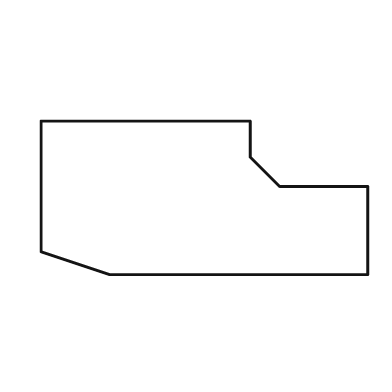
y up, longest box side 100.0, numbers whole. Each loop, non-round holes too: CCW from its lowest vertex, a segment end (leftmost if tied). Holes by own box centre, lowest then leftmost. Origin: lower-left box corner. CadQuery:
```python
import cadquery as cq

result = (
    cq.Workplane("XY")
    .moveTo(21.0, 0.0)
    .lineTo(100.0, 0.0)
    .lineTo(100.0, 27.0)
    .lineTo(73.0, 27.0)
    .lineTo(64.0, 36.0)
    .lineTo(64.0, 47.0)
    .lineTo(0.0, 47.0)
    .lineTo(0.0, 7.0)
    .close()
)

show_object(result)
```